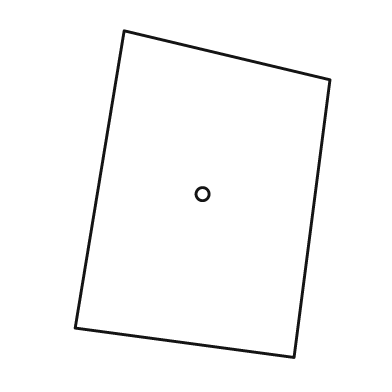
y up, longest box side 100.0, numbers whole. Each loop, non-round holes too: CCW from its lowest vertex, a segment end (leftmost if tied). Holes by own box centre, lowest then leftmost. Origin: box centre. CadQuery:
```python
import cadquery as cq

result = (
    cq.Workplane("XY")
    .moveTo(28.0, -50.0)
    .lineTo(39.0, 35.0)
    .lineTo(-24.0, 50.0)
    .lineTo(-39.0, -41.0)
    .close()
    .moveTo(0.0, 0.0)
    .circle(2.0)
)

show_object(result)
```